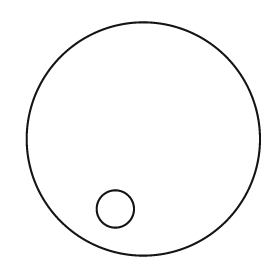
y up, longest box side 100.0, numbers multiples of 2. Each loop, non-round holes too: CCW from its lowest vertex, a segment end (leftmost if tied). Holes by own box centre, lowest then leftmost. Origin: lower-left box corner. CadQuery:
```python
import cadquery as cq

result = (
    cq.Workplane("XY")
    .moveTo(50.0, 50.0)
    .circle(50.0)
    .moveTo(38.0, 20.0)
    .circle(8.0)
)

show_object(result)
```